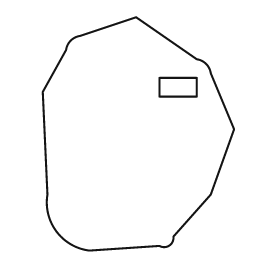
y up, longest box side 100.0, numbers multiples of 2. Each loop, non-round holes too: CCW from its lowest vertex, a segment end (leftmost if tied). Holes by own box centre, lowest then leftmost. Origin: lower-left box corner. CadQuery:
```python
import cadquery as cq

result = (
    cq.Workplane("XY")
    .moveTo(20.0, 0.0)
    .lineTo(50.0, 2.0)
    .threePointArc((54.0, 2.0), (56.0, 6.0))
    .lineTo(72.0, 24.0)
    .lineTo(82.0, 52.0)
    .lineTo(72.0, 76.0)
    .threePointArc((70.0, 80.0), (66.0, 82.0))
    .lineTo(40.0, 100.0)
    .lineTo(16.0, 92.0)
    .threePointArc((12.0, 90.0), (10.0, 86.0))
    .lineTo(0.0, 68.0)
    .lineTo(2.0, 24.0)
    .threePointArc((6.0, 8.0), (20.0, 0.0))
    .close()
    .moveTo(50.0, 66.0)
    .lineTo(66.0, 66.0)
    .lineTo(66.0, 74.0)
    .lineTo(50.0, 74.0)
    .close()
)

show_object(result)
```